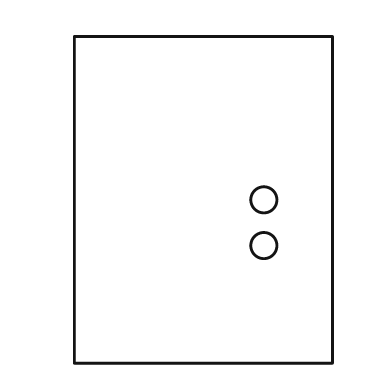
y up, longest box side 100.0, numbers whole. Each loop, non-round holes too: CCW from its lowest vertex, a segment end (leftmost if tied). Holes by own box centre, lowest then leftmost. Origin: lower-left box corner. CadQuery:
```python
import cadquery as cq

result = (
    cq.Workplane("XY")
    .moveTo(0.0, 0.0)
    .lineTo(79.0, 0.0)
    .lineTo(79.0, 100.0)
    .lineTo(0.0, 100.0)
    .close()
    .moveTo(58.0, 36.0)
    .circle(4.0)
    .moveTo(58.0, 50.0)
    .circle(4.0)
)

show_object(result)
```